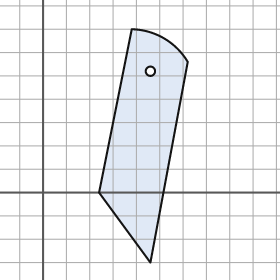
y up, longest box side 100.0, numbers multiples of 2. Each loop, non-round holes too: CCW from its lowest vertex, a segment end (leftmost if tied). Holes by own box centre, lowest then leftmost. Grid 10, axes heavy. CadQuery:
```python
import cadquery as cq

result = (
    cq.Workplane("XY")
    .moveTo(46.0, -30.0)
    .lineTo(62.0, 56.0)
    .threePointArc((52.0, 66.0), (38.0, 70.0))
    .lineTo(24.0, 0.0)
    .close()
    .moveTo(46.0, 52.0)
    .circle(2.0)
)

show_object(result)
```